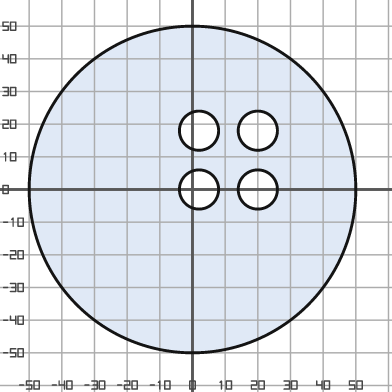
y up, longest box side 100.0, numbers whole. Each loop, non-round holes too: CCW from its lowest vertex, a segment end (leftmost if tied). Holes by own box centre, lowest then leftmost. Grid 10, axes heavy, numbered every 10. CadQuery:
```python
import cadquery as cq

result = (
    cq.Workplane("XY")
    .moveTo(0.0, 0.0)
    .circle(50.0)
    .moveTo(2.0, 0.0)
    .circle(6.0)
    .moveTo(20.0, 0.0)
    .circle(6.0)
    .moveTo(2.0, 18.0)
    .circle(6.0)
    .moveTo(20.0, 18.0)
    .circle(6.0)
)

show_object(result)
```